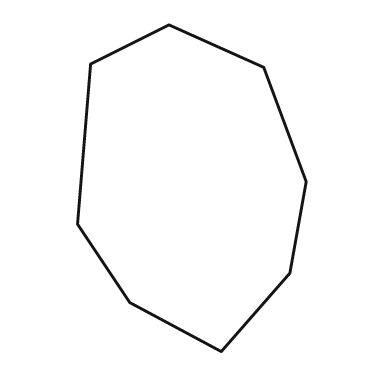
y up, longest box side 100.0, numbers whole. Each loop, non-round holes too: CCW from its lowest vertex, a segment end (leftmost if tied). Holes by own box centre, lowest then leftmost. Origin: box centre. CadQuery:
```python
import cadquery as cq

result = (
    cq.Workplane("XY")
    .moveTo(9.0, -50.0)
    .lineTo(30.0, -26.0)
    .lineTo(35.0, 2.0)
    .lineTo(22.0, 37.0)
    .lineTo(-7.0, 50.0)
    .lineTo(-31.0, 38.0)
    .lineTo(-35.0, -11.0)
    .lineTo(-19.0, -35.0)
    .close()
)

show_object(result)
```